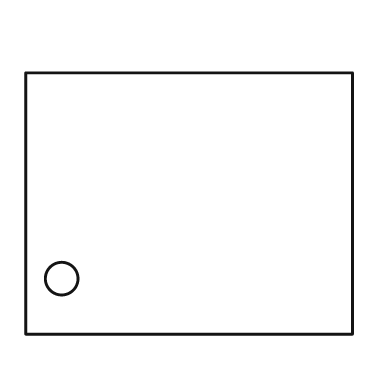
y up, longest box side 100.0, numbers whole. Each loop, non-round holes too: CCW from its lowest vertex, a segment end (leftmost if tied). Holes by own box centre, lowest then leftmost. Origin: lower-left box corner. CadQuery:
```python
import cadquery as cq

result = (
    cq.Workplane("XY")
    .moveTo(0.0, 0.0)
    .lineTo(100.0, 0.0)
    .lineTo(100.0, 80.0)
    .lineTo(0.0, 80.0)
    .close()
    .moveTo(11.0, 17.0)
    .circle(5.0)
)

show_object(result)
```